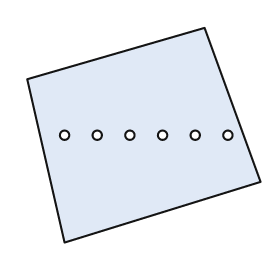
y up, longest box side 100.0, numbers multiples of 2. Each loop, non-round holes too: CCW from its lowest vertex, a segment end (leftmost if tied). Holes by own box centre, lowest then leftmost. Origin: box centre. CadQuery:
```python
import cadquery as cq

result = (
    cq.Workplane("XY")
    .moveTo(-34.0, -46.0)
    .lineTo(50.0, -20.0)
    .lineTo(26.0, 46.0)
    .lineTo(-50.0, 24.0)
    .close()
    .moveTo(-34.0, 0.0)
    .circle(2.0)
    .moveTo(-20.0, 0.0)
    .circle(2.0)
    .moveTo(-6.0, 0.0)
    .circle(2.0)
    .moveTo(8.0, 0.0)
    .circle(2.0)
    .moveTo(22.0, 0.0)
    .circle(2.0)
    .moveTo(36.0, 0.0)
    .circle(2.0)
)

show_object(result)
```